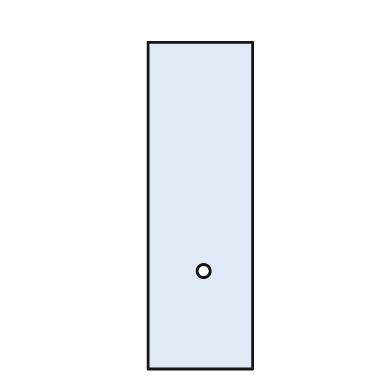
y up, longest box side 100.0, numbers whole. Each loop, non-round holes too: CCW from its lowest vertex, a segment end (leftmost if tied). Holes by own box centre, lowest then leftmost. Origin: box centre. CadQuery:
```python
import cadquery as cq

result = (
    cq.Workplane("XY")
    .moveTo(-16.0, -50.0)
    .lineTo(16.0, -50.0)
    .lineTo(16.0, 50.0)
    .lineTo(-16.0, 50.0)
    .close()
    .moveTo(1.0, -20.0)
    .circle(2.0)
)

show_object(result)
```